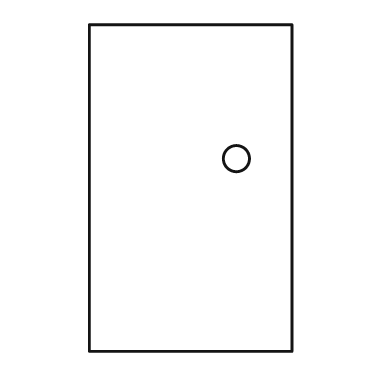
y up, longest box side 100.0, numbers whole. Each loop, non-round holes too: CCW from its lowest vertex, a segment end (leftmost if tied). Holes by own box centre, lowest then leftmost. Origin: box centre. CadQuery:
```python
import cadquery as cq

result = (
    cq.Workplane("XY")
    .moveTo(-31.0, -50.0)
    .lineTo(31.0, -50.0)
    .lineTo(31.0, 50.0)
    .lineTo(-31.0, 50.0)
    .close()
    .moveTo(14.0, 9.0)
    .circle(4.0)
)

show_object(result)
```